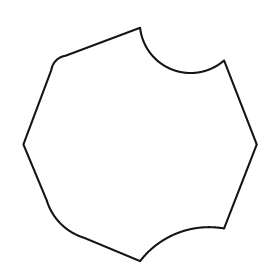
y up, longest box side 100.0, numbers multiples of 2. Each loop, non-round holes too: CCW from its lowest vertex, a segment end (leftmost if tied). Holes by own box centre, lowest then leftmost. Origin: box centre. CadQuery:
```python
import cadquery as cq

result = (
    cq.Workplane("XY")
    .moveTo(0.0, -50.0)
    .threePointArc((16.0, -38.0), (36.0, -36.0))
    .lineTo(50.0, 0.0)
    .lineTo(36.0, 36.0)
    .threePointArc((14.0, 32.0), (0.0, 50.0))
    .lineTo(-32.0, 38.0)
    .threePointArc((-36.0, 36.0), (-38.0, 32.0))
    .lineTo(-50.0, 0.0)
    .lineTo(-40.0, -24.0)
    .threePointArc((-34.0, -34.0), (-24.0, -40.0))
    .close()
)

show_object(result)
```